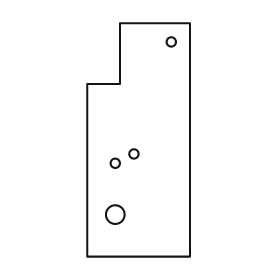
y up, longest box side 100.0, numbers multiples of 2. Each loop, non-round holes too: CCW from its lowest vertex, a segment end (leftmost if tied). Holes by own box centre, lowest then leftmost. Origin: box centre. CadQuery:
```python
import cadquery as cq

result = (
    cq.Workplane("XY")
    .moveTo(-22.0, -50.0)
    .lineTo(22.0, -50.0)
    .lineTo(22.0, 50.0)
    .lineTo(-8.0, 50.0)
    .lineTo(-8.0, 24.0)
    .lineTo(-22.0, 24.0)
    .close()
    .moveTo(-10.0, -32.0)
    .circle(4.0)
    .moveTo(-10.0, -10.0)
    .circle(2.0)
    .moveTo(-2.0, -6.0)
    .circle(2.0)
    .moveTo(14.0, 42.0)
    .circle(2.0)
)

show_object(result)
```